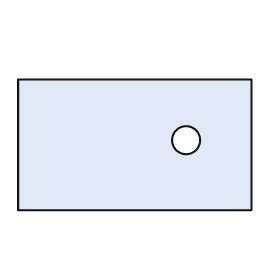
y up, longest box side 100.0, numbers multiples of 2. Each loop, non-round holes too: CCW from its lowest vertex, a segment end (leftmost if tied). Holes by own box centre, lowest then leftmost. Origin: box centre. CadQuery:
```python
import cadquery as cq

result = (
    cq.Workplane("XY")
    .moveTo(-50.0, -28.0)
    .lineTo(50.0, -28.0)
    .lineTo(50.0, 28.0)
    .lineTo(-50.0, 28.0)
    .close()
    .moveTo(22.0, 2.0)
    .circle(6.0)
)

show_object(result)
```